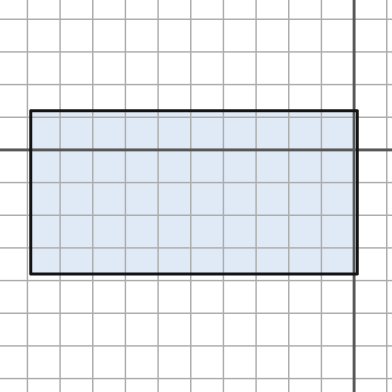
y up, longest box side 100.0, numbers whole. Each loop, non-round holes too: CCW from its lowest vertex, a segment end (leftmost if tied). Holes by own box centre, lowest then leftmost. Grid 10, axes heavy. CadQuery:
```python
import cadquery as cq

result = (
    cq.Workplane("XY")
    .moveTo(-99.0, -38.0)
    .lineTo(1.0, -38.0)
    .lineTo(1.0, 12.0)
    .lineTo(-99.0, 12.0)
    .close()
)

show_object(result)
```